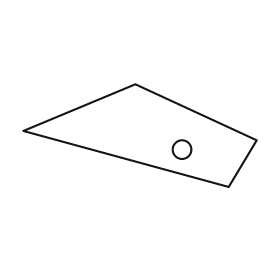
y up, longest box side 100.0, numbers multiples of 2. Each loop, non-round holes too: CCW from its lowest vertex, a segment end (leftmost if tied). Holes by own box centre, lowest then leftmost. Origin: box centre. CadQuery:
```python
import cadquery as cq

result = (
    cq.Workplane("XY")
    .moveTo(38.0, -22.0)
    .lineTo(50.0, -2.0)
    .lineTo(-2.0, 22.0)
    .lineTo(-50.0, 2.0)
    .close()
    .moveTo(18.0, -6.0)
    .circle(4.0)
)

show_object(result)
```